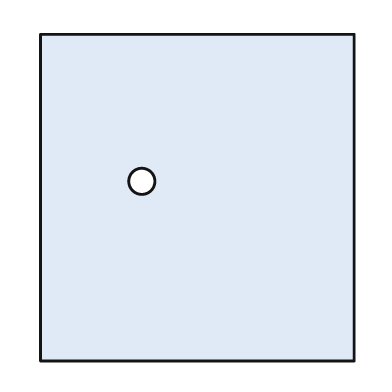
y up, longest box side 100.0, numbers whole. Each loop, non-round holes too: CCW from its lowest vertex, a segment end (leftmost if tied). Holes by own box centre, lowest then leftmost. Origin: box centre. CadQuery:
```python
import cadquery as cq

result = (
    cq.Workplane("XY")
    .moveTo(-48.0, -50.0)
    .lineTo(48.0, -50.0)
    .lineTo(48.0, 50.0)
    .lineTo(-48.0, 50.0)
    .close()
    .moveTo(-17.0, 5.0)
    .circle(4.0)
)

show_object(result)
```